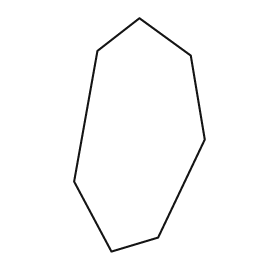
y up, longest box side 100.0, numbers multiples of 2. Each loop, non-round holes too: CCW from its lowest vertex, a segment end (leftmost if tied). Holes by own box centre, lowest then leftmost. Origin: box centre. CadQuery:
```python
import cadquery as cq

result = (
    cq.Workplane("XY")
    .moveTo(-12.0, -50.0)
    .lineTo(8.0, -44.0)
    .lineTo(28.0, -2.0)
    .lineTo(22.0, 34.0)
    .lineTo(0.0, 50.0)
    .lineTo(-18.0, 36.0)
    .lineTo(-28.0, -20.0)
    .close()
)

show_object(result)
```